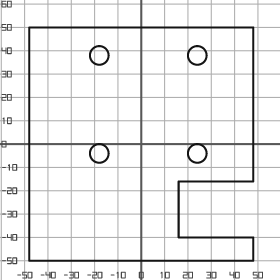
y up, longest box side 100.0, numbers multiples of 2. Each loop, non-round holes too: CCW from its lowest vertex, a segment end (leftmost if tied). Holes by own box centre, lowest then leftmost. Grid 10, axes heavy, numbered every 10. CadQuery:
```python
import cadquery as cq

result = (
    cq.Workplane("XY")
    .moveTo(-48.0, -50.0)
    .lineTo(48.0, -50.0)
    .lineTo(48.0, -40.0)
    .lineTo(16.0, -40.0)
    .lineTo(16.0, -16.0)
    .lineTo(48.0, -16.0)
    .lineTo(48.0, 50.0)
    .lineTo(-48.0, 50.0)
    .close()
    .moveTo(-18.0, -4.0)
    .circle(4.0)
    .moveTo(24.0, -4.0)
    .circle(4.0)
    .moveTo(-18.0, 38.0)
    .circle(4.0)
    .moveTo(24.0, 38.0)
    .circle(4.0)
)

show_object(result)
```